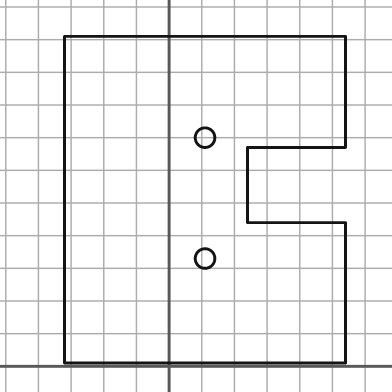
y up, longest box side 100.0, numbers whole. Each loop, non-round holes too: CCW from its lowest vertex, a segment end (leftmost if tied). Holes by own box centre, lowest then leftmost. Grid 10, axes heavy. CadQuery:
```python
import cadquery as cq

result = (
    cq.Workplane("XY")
    .moveTo(-32.0, 1.0)
    .lineTo(54.0, 1.0)
    .lineTo(54.0, 44.0)
    .lineTo(24.0, 44.0)
    .lineTo(24.0, 67.0)
    .lineTo(54.0, 67.0)
    .lineTo(54.0, 101.0)
    .lineTo(-32.0, 101.0)
    .close()
    .moveTo(11.0, 33.0)
    .circle(3.0)
    .moveTo(11.0, 70.0)
    .circle(3.0)
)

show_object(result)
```